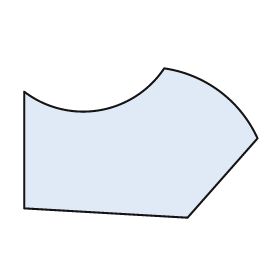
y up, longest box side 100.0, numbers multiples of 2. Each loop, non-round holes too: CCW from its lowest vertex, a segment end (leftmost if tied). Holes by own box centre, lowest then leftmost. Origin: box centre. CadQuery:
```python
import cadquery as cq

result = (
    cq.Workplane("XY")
    .moveTo(20.0, -32.0)
    .lineTo(50.0, 2.0)
    .threePointArc((34.0, 22.0), (10.0, 32.0))
    .threePointArc((-18.0, 14.0), (-50.0, 22.0))
    .lineTo(-50.0, -28.0)
    .close()
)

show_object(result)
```